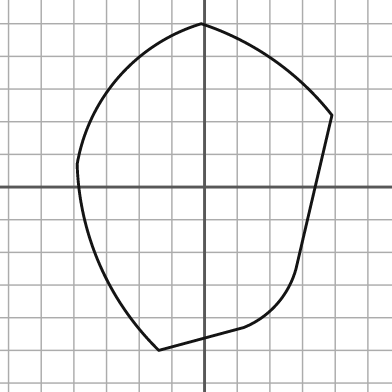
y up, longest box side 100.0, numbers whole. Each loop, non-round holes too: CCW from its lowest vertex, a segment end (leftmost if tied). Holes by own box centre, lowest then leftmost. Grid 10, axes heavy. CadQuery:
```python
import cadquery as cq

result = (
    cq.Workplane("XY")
    .moveTo(-14.0, -50.0)
    .lineTo(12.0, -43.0)
    .threePointArc((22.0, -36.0), (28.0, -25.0))
    .lineTo(39.0, 22.0)
    .threePointArc((21.0, 39.0), (-1.0, 50.0))
    .threePointArc((-26.0, 34.0), (-39.0, 7.0))
    .threePointArc((-32.0, -24.0), (-14.0, -50.0))
    .close()
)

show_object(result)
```